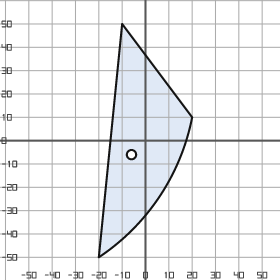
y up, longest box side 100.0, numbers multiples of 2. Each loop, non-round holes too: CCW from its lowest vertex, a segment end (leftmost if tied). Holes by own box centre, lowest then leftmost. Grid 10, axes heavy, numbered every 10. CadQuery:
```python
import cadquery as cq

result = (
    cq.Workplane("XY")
    .moveTo(-20.0, -50.0)
    .threePointArc((6.0, -24.0), (20.0, 10.0))
    .lineTo(-10.0, 50.0)
    .close()
    .moveTo(-6.0, -6.0)
    .circle(2.0)
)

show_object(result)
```